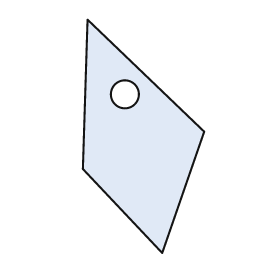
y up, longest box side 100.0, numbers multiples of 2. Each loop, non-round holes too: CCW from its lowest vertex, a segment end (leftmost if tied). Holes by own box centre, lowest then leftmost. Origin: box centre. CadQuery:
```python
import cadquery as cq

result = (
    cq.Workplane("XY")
    .moveTo(8.0, -50.0)
    .lineTo(26.0, 2.0)
    .lineTo(-24.0, 50.0)
    .lineTo(-26.0, -14.0)
    .close()
    .moveTo(-8.0, 18.0)
    .circle(6.0)
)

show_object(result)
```